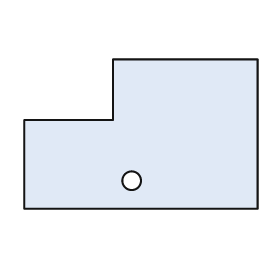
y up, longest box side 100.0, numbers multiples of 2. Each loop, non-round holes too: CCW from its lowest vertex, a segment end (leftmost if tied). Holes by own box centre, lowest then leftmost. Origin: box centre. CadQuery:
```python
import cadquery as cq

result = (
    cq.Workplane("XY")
    .moveTo(-50.0, -32.0)
    .lineTo(50.0, -32.0)
    .lineTo(50.0, 32.0)
    .lineTo(-12.0, 32.0)
    .lineTo(-12.0, 6.0)
    .lineTo(-50.0, 6.0)
    .close()
    .moveTo(-4.0, -20.0)
    .circle(4.0)
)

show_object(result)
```